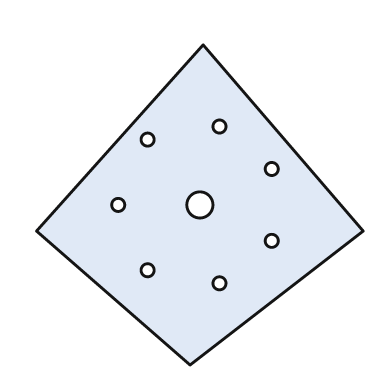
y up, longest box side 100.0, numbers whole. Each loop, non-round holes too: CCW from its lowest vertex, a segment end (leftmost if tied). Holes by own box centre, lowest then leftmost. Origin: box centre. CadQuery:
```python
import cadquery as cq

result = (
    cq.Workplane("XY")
    .moveTo(-3.0, -49.0)
    .lineTo(50.0, -8.0)
    .lineTo(1.0, 49.0)
    .lineTo(-50.0, -8.0)
    .close()
    .moveTo(6.0, -24.0)
    .circle(2.0)
    .moveTo(-16.0, -20.0)
    .circle(2.0)
    .moveTo(22.0, -11.0)
    .circle(2.0)
    .moveTo(-25.0, 0.0)
    .circle(2.0)
    .moveTo(0.0, 0.0)
    .circle(4.0)
    .moveTo(22.0, 11.0)
    .circle(2.0)
    .moveTo(-16.0, 20.0)
    .circle(2.0)
    .moveTo(6.0, 24.0)
    .circle(2.0)
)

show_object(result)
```